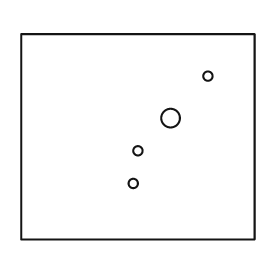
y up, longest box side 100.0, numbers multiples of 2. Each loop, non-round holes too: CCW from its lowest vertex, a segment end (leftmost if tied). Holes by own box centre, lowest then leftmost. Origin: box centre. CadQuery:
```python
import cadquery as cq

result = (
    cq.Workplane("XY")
    .moveTo(-50.0, -44.0)
    .lineTo(50.0, -44.0)
    .lineTo(50.0, 44.0)
    .lineTo(-50.0, 44.0)
    .close()
    .moveTo(-2.0, -20.0)
    .circle(2.0)
    .moveTo(0.0, -6.0)
    .circle(2.0)
    .moveTo(14.0, 8.0)
    .circle(4.0)
    .moveTo(30.0, 26.0)
    .circle(2.0)
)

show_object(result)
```